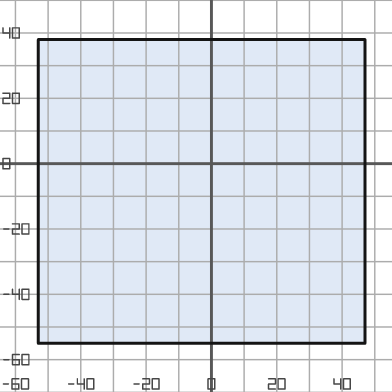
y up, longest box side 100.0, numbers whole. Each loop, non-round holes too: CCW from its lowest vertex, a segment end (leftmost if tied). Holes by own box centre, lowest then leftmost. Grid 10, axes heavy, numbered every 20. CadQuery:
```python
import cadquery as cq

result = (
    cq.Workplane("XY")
    .moveTo(-53.0, -55.0)
    .lineTo(47.0, -55.0)
    .lineTo(47.0, 38.0)
    .lineTo(-53.0, 38.0)
    .close()
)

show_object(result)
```